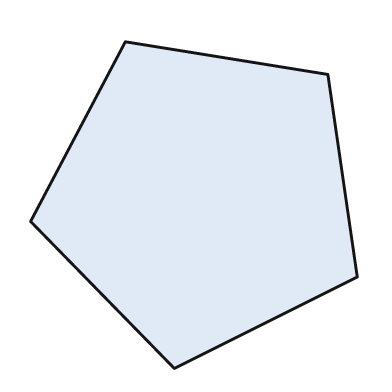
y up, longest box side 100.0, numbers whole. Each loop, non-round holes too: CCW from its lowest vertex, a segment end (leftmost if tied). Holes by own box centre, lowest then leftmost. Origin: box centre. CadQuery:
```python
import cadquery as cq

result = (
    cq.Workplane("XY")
    .moveTo(-6.0, -50.0)
    .lineTo(50.0, -22.0)
    .lineTo(41.0, 40.0)
    .lineTo(-21.0, 50.0)
    .lineTo(-50.0, -5.0)
    .close()
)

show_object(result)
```